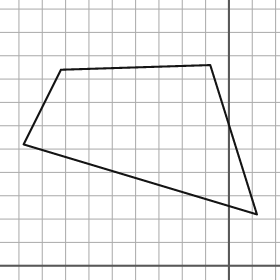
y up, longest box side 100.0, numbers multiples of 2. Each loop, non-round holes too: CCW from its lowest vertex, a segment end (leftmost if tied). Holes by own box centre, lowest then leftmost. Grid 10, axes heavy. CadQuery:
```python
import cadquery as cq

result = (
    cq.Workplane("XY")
    .moveTo(12.0, 22.0)
    .lineTo(-8.0, 86.0)
    .lineTo(-72.0, 84.0)
    .lineTo(-88.0, 52.0)
    .close()
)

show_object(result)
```